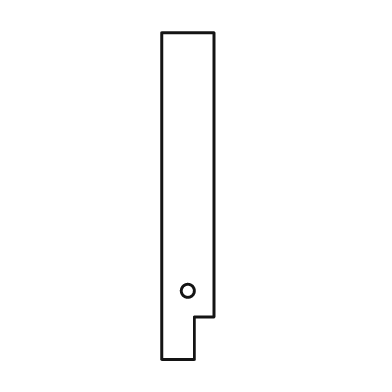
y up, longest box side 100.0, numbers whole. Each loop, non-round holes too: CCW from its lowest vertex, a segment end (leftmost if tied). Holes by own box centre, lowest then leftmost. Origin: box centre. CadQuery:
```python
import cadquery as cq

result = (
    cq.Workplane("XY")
    .moveTo(-8.0, -50.0)
    .lineTo(2.0, -50.0)
    .lineTo(2.0, -37.0)
    .lineTo(8.0, -37.0)
    .lineTo(8.0, 50.0)
    .lineTo(-8.0, 50.0)
    .close()
    .moveTo(0.0, -29.0)
    .circle(2.0)
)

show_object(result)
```